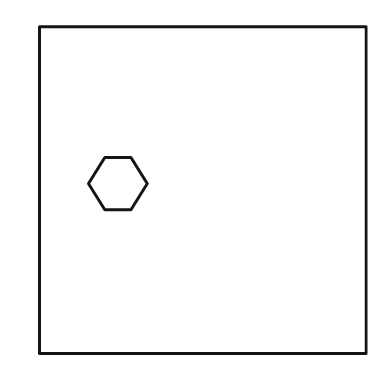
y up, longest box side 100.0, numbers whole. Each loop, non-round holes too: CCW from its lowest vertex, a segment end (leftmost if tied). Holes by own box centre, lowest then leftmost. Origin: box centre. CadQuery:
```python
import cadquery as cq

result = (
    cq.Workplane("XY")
    .moveTo(-50.0, -50.0)
    .lineTo(50.0, -50.0)
    .lineTo(50.0, 50.0)
    .lineTo(-50.0, 50.0)
    .close()
    .moveTo(-30.0, -6.0)
    .lineTo(-22.0, -6.0)
    .lineTo(-17.0, 2.0)
    .lineTo(-22.0, 10.0)
    .lineTo(-30.0, 10.0)
    .lineTo(-35.0, 2.0)
    .close()
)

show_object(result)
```